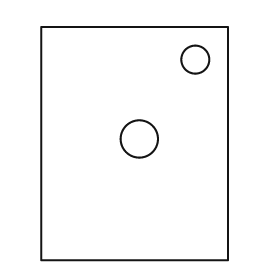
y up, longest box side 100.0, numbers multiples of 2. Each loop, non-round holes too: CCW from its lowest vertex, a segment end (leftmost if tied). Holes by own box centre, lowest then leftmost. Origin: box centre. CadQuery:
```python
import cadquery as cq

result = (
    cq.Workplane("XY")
    .moveTo(-40.0, -50.0)
    .lineTo(40.0, -50.0)
    .lineTo(40.0, 50.0)
    .lineTo(-40.0, 50.0)
    .close()
    .moveTo(2.0, 2.0)
    .circle(8.0)
    .moveTo(26.0, 36.0)
    .circle(6.0)
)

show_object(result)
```